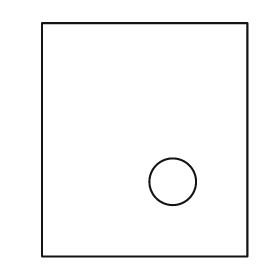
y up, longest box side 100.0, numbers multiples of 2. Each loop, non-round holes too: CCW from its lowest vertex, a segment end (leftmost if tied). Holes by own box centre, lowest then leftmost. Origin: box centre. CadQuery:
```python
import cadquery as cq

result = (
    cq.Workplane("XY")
    .moveTo(-44.0, -50.0)
    .lineTo(44.0, -50.0)
    .lineTo(44.0, 50.0)
    .lineTo(-44.0, 50.0)
    .close()
    .moveTo(12.0, -18.0)
    .circle(10.0)
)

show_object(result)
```